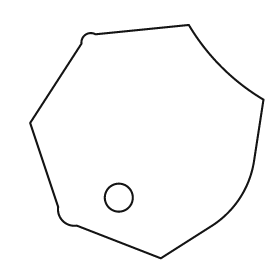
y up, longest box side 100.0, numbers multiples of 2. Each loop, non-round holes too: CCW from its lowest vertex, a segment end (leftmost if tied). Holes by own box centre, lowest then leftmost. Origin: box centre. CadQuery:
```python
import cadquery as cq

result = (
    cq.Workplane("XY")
    .moveTo(6.0, -50.0)
    .lineTo(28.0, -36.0)
    .threePointArc((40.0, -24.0), (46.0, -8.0))
    .lineTo(50.0, 18.0)
    .threePointArc((32.0, 32.0), (18.0, 50.0))
    .lineTo(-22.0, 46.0)
    .threePointArc((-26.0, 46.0), (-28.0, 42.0))
    .lineTo(-50.0, 8.0)
    .lineTo(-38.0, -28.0)
    .threePointArc((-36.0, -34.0), (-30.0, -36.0))
    .close()
    .moveTo(-12.0, -24.0)
    .circle(6.0)
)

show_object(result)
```